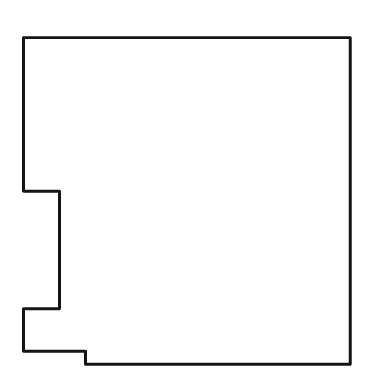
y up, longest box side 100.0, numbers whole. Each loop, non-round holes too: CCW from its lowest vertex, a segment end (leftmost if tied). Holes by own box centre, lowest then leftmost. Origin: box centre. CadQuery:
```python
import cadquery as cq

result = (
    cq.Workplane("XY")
    .moveTo(-31.0, -50.0)
    .lineTo(50.0, -50.0)
    .lineTo(50.0, 50.0)
    .lineTo(-50.0, 50.0)
    .lineTo(-50.0, 3.0)
    .lineTo(-39.0, 3.0)
    .lineTo(-39.0, -33.0)
    .lineTo(-50.0, -33.0)
    .lineTo(-50.0, -46.0)
    .lineTo(-31.0, -46.0)
    .close()
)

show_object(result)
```